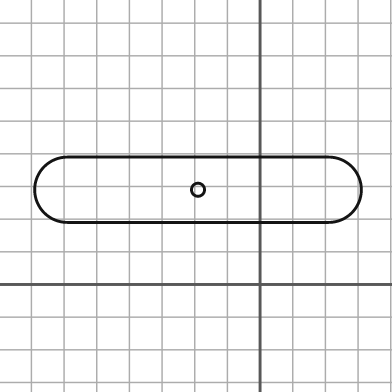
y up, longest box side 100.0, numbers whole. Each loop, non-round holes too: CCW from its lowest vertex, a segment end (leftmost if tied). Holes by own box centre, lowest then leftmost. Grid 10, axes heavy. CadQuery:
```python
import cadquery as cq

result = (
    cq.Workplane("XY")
    .moveTo(-59.0, 19.0)
    .lineTo(21.0, 19.0)
    .threePointArc((31.0, 29.0), (21.0, 39.0))
    .lineTo(-59.0, 39.0)
    .threePointArc((-69.0, 29.0), (-59.0, 19.0))
    .close()
    .moveTo(-19.0, 29.0)
    .circle(2.0)
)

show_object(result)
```